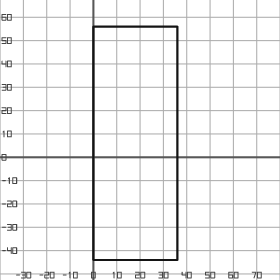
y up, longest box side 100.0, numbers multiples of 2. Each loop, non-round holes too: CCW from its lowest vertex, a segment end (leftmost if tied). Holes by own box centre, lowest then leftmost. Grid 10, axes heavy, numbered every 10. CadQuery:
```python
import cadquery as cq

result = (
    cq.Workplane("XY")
    .moveTo(0.0, -44.0)
    .lineTo(36.0, -44.0)
    .lineTo(36.0, 56.0)
    .lineTo(0.0, 56.0)
    .close()
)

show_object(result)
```